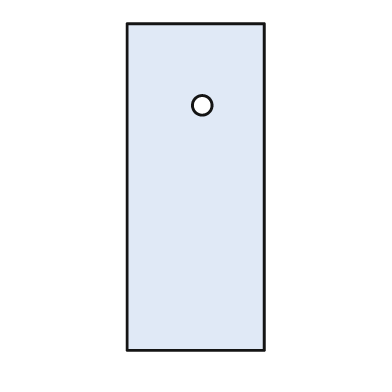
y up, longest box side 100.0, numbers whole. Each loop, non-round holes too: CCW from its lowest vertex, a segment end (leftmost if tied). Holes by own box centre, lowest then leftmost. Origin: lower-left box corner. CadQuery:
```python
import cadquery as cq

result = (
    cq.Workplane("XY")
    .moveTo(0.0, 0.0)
    .lineTo(42.0, 0.0)
    .lineTo(42.0, 100.0)
    .lineTo(0.0, 100.0)
    .close()
    .moveTo(23.0, 75.0)
    .circle(3.0)
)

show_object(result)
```